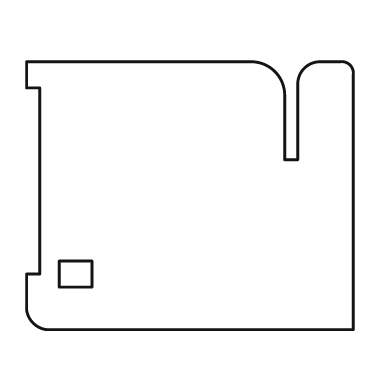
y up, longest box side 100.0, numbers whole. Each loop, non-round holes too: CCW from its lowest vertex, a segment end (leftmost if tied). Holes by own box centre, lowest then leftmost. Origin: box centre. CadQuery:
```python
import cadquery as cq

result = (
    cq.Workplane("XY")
    .moveTo(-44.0, -41.0)
    .lineTo(50.0, -41.0)
    .lineTo(50.0, 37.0)
    .threePointArc((49.0, 40.0), (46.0, 41.0))
    .lineTo(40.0, 41.0)
    .threePointArc((35.0, 39.0), (33.0, 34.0))
    .lineTo(33.0, 11.0)
    .lineTo(29.0, 11.0)
    .lineTo(29.0, 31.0)
    .threePointArc((26.0, 38.0), (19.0, 41.0))
    .lineTo(-50.0, 41.0)
    .lineTo(-50.0, 33.0)
    .lineTo(-46.0, 33.0)
    .lineTo(-46.0, -24.0)
    .lineTo(-50.0, -24.0)
    .lineTo(-50.0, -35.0)
    .threePointArc((-48.0, -39.0), (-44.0, -41.0))
    .close()
    .moveTo(-40.0, -28.0)
    .lineTo(-30.0, -28.0)
    .lineTo(-30.0, -20.0)
    .lineTo(-40.0, -20.0)
    .close()
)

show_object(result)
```